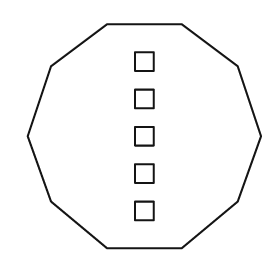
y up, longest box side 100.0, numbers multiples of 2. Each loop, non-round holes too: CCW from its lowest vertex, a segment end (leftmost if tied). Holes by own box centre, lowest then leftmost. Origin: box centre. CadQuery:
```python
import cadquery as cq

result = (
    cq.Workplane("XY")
    .moveTo(-16.0, -48.0)
    .lineTo(16.0, -48.0)
    .lineTo(40.0, -28.0)
    .lineTo(50.0, 0.0)
    .lineTo(40.0, 30.0)
    .lineTo(16.0, 48.0)
    .lineTo(-16.0, 48.0)
    .lineTo(-40.0, 30.0)
    .lineTo(-50.0, 0.0)
    .lineTo(-40.0, -28.0)
    .close()
    .moveTo(-4.0, -36.0)
    .lineTo(4.0, -36.0)
    .lineTo(4.0, -28.0)
    .lineTo(-4.0, -28.0)
    .close()
    .moveTo(-4.0, -20.0)
    .lineTo(4.0, -20.0)
    .lineTo(4.0, -12.0)
    .lineTo(-4.0, -12.0)
    .close()
    .moveTo(-4.0, -4.0)
    .lineTo(4.0, -4.0)
    .lineTo(4.0, 4.0)
    .lineTo(-4.0, 4.0)
    .close()
    .moveTo(-4.0, 12.0)
    .lineTo(4.0, 12.0)
    .lineTo(4.0, 20.0)
    .lineTo(-4.0, 20.0)
    .close()
    .moveTo(-4.0, 28.0)
    .lineTo(4.0, 28.0)
    .lineTo(4.0, 36.0)
    .lineTo(-4.0, 36.0)
    .close()
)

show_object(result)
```